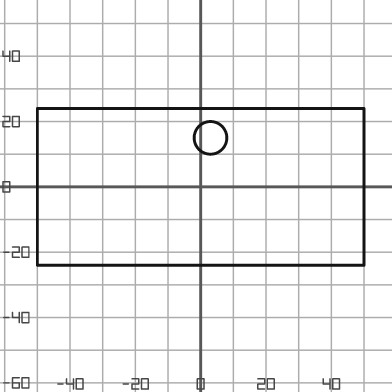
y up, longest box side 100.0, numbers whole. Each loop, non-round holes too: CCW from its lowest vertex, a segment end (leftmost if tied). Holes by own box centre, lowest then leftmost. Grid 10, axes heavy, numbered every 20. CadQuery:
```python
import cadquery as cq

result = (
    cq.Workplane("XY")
    .moveTo(-50.0, -24.0)
    .lineTo(50.0, -24.0)
    .lineTo(50.0, 24.0)
    .lineTo(-50.0, 24.0)
    .close()
    .moveTo(3.0, 15.0)
    .circle(5.0)
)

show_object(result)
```